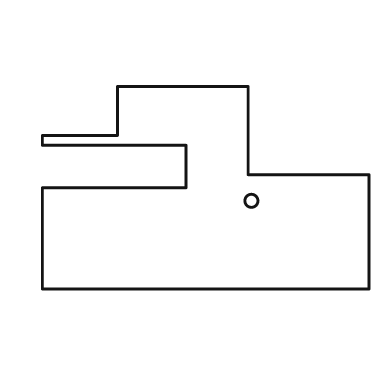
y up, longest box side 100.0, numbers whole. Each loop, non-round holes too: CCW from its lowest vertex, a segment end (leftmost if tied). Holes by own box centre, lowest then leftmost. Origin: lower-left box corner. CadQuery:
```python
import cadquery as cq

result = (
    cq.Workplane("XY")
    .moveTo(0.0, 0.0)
    .lineTo(100.0, 0.0)
    .lineTo(100.0, 35.0)
    .lineTo(63.0, 35.0)
    .lineTo(63.0, 62.0)
    .lineTo(23.0, 62.0)
    .lineTo(23.0, 47.0)
    .lineTo(0.0, 47.0)
    .lineTo(0.0, 44.0)
    .lineTo(44.0, 44.0)
    .lineTo(44.0, 31.0)
    .lineTo(0.0, 31.0)
    .close()
    .moveTo(64.0, 27.0)
    .circle(2.0)
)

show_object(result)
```